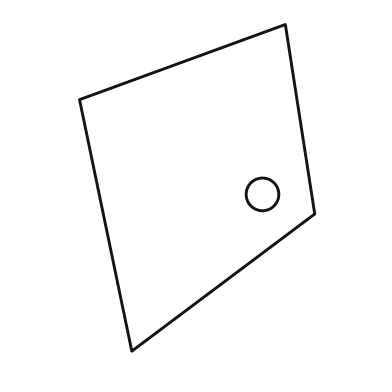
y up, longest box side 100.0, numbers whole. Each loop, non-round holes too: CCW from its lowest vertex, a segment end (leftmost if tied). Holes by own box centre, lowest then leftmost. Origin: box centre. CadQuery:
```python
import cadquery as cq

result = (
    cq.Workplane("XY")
    .moveTo(-20.0, -50.0)
    .lineTo(36.0, -8.0)
    .lineTo(27.0, 50.0)
    .lineTo(-36.0, 27.0)
    .close()
    .moveTo(20.0, -2.0)
    .circle(5.0)
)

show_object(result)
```